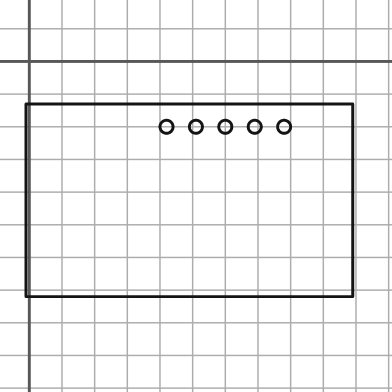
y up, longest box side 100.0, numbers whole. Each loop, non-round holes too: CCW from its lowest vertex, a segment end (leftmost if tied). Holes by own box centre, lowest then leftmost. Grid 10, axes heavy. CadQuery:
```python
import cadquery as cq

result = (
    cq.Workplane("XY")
    .moveTo(-1.0, -72.0)
    .lineTo(99.0, -72.0)
    .lineTo(99.0, -13.0)
    .lineTo(-1.0, -13.0)
    .close()
    .moveTo(42.0, -20.0)
    .circle(2.0)
    .moveTo(51.0, -20.0)
    .circle(2.0)
    .moveTo(60.0, -20.0)
    .circle(2.0)
    .moveTo(69.0, -20.0)
    .circle(2.0)
    .moveTo(78.0, -20.0)
    .circle(2.0)
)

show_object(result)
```